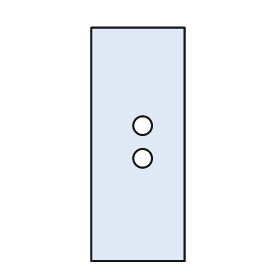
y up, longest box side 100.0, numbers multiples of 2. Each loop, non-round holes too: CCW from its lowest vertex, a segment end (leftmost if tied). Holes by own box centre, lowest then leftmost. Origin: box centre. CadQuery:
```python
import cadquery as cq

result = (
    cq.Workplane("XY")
    .moveTo(-20.0, -50.0)
    .lineTo(20.0, -50.0)
    .lineTo(20.0, 50.0)
    .lineTo(-20.0, 50.0)
    .close()
    .moveTo(2.0, -6.0)
    .circle(4.0)
    .moveTo(2.0, 8.0)
    .circle(4.0)
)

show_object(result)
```